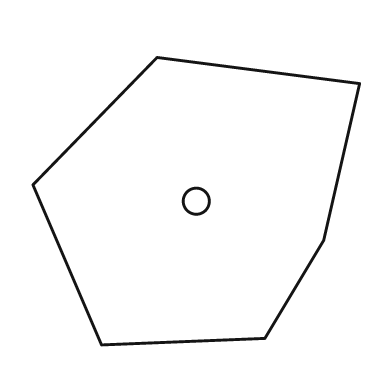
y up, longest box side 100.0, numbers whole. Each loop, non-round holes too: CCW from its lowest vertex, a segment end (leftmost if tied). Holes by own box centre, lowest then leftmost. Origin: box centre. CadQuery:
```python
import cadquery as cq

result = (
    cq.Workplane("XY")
    .moveTo(-29.0, -44.0)
    .lineTo(21.0, -42.0)
    .lineTo(39.0, -12.0)
    .lineTo(50.0, 36.0)
    .lineTo(-12.0, 44.0)
    .lineTo(-50.0, 5.0)
    .close()
    .moveTo(0.0, 0.0)
    .circle(4.0)
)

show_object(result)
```